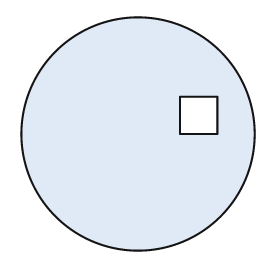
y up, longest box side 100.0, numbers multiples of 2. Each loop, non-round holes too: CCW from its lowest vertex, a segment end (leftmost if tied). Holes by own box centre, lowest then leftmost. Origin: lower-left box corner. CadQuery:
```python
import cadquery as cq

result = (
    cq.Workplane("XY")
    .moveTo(50.0, 50.0)
    .circle(50.0)
    .moveTo(68.0, 50.0)
    .lineTo(84.0, 50.0)
    .lineTo(84.0, 66.0)
    .lineTo(68.0, 66.0)
    .close()
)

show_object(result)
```